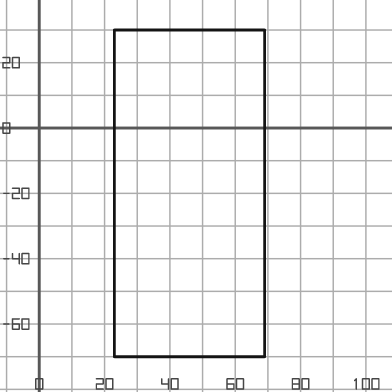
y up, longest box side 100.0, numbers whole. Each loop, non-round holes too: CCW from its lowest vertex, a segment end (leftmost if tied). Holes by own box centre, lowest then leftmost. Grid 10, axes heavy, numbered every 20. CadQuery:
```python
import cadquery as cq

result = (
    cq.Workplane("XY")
    .moveTo(23.0, -70.0)
    .lineTo(69.0, -70.0)
    .lineTo(69.0, 30.0)
    .lineTo(23.0, 30.0)
    .close()
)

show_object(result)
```